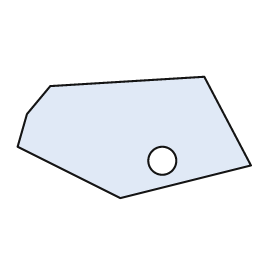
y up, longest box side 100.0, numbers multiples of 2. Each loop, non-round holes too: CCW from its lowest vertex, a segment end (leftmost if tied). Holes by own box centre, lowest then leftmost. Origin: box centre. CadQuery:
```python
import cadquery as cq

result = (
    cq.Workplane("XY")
    .moveTo(-6.0, -26.0)
    .lineTo(50.0, -12.0)
    .lineTo(30.0, 26.0)
    .lineTo(-36.0, 22.0)
    .lineTo(-46.0, 10.0)
    .lineTo(-50.0, -4.0)
    .close()
    .moveTo(12.0, -10.0)
    .circle(6.0)
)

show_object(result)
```